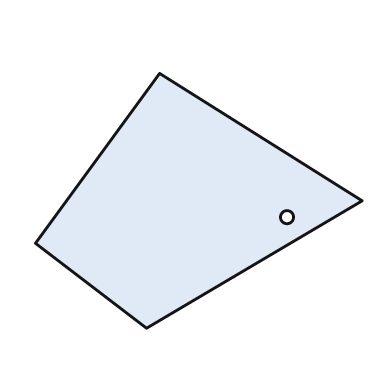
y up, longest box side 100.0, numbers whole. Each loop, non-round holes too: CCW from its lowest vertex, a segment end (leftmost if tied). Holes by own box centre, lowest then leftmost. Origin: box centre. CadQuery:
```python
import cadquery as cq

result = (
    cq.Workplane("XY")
    .moveTo(-16.0, -39.0)
    .lineTo(50.0, 0.0)
    .lineTo(-12.0, 39.0)
    .lineTo(-50.0, -13.0)
    .close()
    .moveTo(27.0, -5.0)
    .circle(2.0)
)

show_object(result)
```